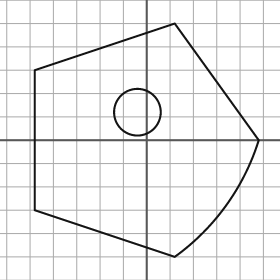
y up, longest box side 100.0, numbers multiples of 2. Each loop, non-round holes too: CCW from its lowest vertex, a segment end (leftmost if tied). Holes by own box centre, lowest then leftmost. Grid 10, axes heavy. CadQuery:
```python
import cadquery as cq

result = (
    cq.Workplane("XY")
    .moveTo(12.0, -50.0)
    .threePointArc((34.0, -28.0), (48.0, 0.0))
    .lineTo(12.0, 50.0)
    .lineTo(-48.0, 30.0)
    .lineTo(-48.0, -30.0)
    .close()
    .moveTo(-4.0, 12.0)
    .circle(10.0)
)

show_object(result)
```